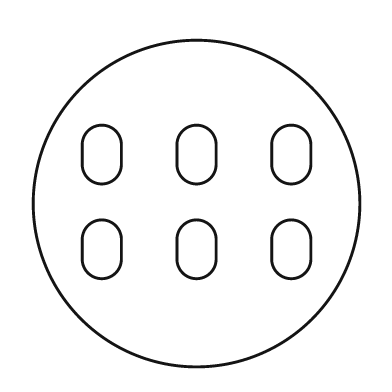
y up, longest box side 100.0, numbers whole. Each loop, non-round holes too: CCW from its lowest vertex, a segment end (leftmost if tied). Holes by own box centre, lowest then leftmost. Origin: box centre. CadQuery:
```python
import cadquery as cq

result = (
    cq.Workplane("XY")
    .moveTo(0.0, 0.0)
    .circle(50.0)
    .moveTo(-35.0, -17.0)
    .threePointArc((-29.0, -23.0), (-23.0, -17.0))
    .lineTo(-23.0, -11.0)
    .threePointArc((-29.0, -5.0), (-35.0, -11.0))
    .close()
    .moveTo(-6.0, -17.0)
    .threePointArc((0.0, -23.0), (6.0, -17.0))
    .lineTo(6.0, -11.0)
    .threePointArc((0.0, -5.0), (-6.0, -11.0))
    .close()
    .moveTo(23.0, -17.0)
    .threePointArc((29.0, -23.0), (35.0, -17.0))
    .lineTo(35.0, -11.0)
    .threePointArc((29.0, -5.0), (23.0, -11.0))
    .close()
    .moveTo(-35.0, 12.0)
    .threePointArc((-29.0, 6.0), (-23.0, 12.0))
    .lineTo(-23.0, 18.0)
    .threePointArc((-29.0, 24.0), (-35.0, 18.0))
    .close()
    .moveTo(-6.0, 12.0)
    .threePointArc((0.0, 6.0), (6.0, 12.0))
    .lineTo(6.0, 18.0)
    .threePointArc((0.0, 24.0), (-6.0, 18.0))
    .close()
    .moveTo(23.0, 12.0)
    .threePointArc((29.0, 6.0), (35.0, 12.0))
    .lineTo(35.0, 18.0)
    .threePointArc((29.0, 24.0), (23.0, 18.0))
    .close()
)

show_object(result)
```